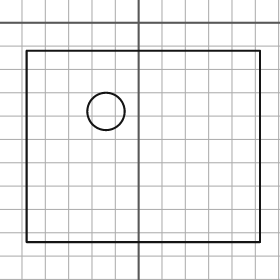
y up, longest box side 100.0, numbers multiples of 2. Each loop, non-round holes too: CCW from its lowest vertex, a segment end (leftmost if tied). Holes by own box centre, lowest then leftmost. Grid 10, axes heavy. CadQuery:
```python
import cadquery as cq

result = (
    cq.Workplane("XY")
    .moveTo(-48.0, -94.0)
    .lineTo(52.0, -94.0)
    .lineTo(52.0, -12.0)
    .lineTo(-48.0, -12.0)
    .close()
    .moveTo(-14.0, -38.0)
    .circle(8.0)
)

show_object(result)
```